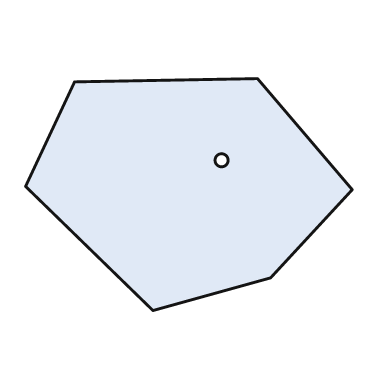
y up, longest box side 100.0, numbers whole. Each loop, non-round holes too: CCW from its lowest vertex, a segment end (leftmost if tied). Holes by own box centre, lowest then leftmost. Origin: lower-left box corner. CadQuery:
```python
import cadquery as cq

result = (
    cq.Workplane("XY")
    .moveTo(39.0, 0.0)
    .lineTo(75.0, 10.0)
    .lineTo(100.0, 37.0)
    .lineTo(71.0, 71.0)
    .lineTo(15.0, 70.0)
    .lineTo(0.0, 38.0)
    .close()
    .moveTo(60.0, 46.0)
    .circle(2.0)
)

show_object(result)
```